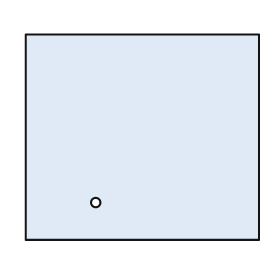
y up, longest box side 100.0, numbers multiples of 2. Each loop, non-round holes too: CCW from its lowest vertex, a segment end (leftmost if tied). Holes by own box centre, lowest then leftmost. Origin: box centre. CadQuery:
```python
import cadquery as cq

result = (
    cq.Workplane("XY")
    .moveTo(-50.0, -44.0)
    .lineTo(50.0, -44.0)
    .lineTo(50.0, 44.0)
    .lineTo(-50.0, 44.0)
    .close()
    .moveTo(-20.0, -28.0)
    .circle(2.0)
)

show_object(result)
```